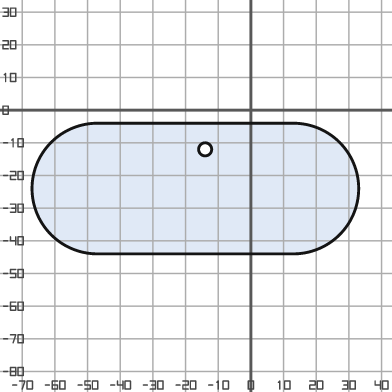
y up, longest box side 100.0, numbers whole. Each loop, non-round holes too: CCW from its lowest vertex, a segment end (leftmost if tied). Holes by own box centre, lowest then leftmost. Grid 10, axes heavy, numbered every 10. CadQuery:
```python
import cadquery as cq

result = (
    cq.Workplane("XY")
    .moveTo(-47.0, -44.0)
    .lineTo(13.0, -44.0)
    .threePointArc((33.0, -24.0), (13.0, -4.0))
    .lineTo(-47.0, -4.0)
    .threePointArc((-67.0, -24.0), (-47.0, -44.0))
    .close()
    .moveTo(-14.0, -12.0)
    .circle(2.0)
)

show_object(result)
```